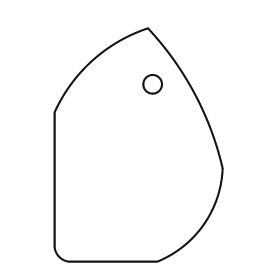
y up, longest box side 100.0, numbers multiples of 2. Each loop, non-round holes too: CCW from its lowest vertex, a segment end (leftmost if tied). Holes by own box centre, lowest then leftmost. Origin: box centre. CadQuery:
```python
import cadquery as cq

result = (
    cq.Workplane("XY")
    .moveTo(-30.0, -50.0)
    .lineTo(8.0, -50.0)
    .threePointArc((28.0, -34.0), (36.0, -10.0))
    .threePointArc((24.0, 22.0), (4.0, 50.0))
    .threePointArc((-20.0, 36.0), (-36.0, 14.0))
    .lineTo(-36.0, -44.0)
    .threePointArc((-34.0, -48.0), (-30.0, -50.0))
    .close()
    .moveTo(6.0, 26.0)
    .circle(4.0)
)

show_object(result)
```